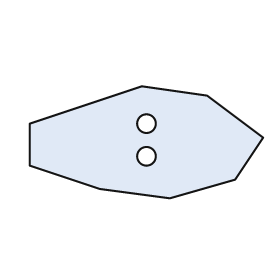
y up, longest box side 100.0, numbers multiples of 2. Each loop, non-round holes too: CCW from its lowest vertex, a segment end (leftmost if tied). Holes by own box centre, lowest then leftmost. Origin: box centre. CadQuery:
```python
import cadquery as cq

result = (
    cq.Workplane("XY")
    .moveTo(10.0, -24.0)
    .lineTo(38.0, -16.0)
    .lineTo(50.0, 2.0)
    .lineTo(26.0, 20.0)
    .lineTo(-2.0, 24.0)
    .lineTo(-50.0, 8.0)
    .lineTo(-50.0, -10.0)
    .lineTo(-20.0, -20.0)
    .close()
    .moveTo(0.0, -6.0)
    .circle(4.0)
    .moveTo(0.0, 8.0)
    .circle(4.0)
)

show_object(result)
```